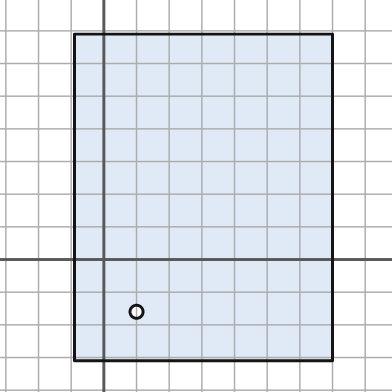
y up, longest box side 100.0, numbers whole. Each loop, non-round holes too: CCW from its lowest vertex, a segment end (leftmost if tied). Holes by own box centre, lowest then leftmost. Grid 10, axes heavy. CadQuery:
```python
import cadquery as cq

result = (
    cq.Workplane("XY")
    .moveTo(-9.0, -31.0)
    .lineTo(70.0, -31.0)
    .lineTo(70.0, 69.0)
    .lineTo(-9.0, 69.0)
    .close()
    .moveTo(10.0, -16.0)
    .circle(2.0)
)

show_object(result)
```